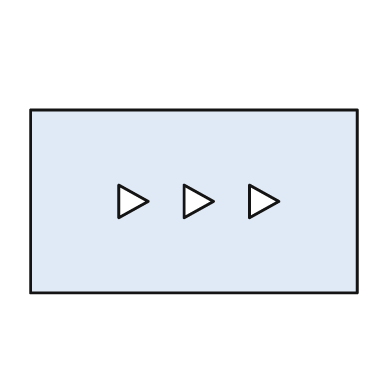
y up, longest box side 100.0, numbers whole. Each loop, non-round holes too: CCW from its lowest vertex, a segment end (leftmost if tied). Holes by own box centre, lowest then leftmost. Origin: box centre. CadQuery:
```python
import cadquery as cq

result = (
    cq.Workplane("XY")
    .moveTo(-50.0, -28.0)
    .lineTo(50.0, -28.0)
    .lineTo(50.0, 28.0)
    .lineTo(-50.0, 28.0)
    .close()
    .moveTo(-23.0, -5.0)
    .lineTo(-14.0, 0.0)
    .lineTo(-23.0, 5.0)
    .close()
    .moveTo(-3.0, -5.0)
    .lineTo(6.0, 0.0)
    .lineTo(-3.0, 5.0)
    .close()
    .moveTo(17.0, -5.0)
    .lineTo(26.0, 0.0)
    .lineTo(17.0, 5.0)
    .close()
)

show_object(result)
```